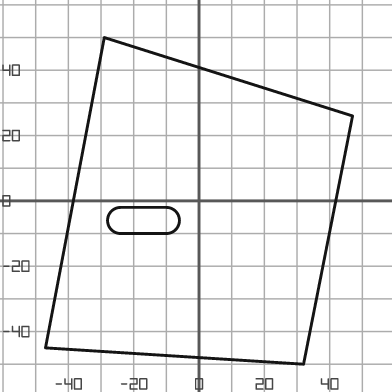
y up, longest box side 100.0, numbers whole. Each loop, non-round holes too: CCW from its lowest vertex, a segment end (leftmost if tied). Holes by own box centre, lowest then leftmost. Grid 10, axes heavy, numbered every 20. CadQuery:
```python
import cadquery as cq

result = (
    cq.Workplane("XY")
    .moveTo(32.0, -50.0)
    .lineTo(47.0, 26.0)
    .lineTo(-29.0, 50.0)
    .lineTo(-47.0, -45.0)
    .close()
    .moveTo(-24.0, -10.0)
    .lineTo(-10.0, -10.0)
    .threePointArc((-6.0, -6.0), (-10.0, -2.0))
    .lineTo(-24.0, -2.0)
    .threePointArc((-28.0, -6.0), (-24.0, -10.0))
    .close()
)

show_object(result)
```